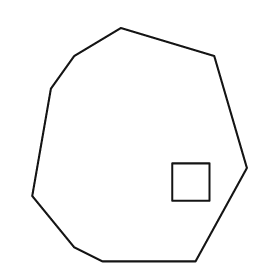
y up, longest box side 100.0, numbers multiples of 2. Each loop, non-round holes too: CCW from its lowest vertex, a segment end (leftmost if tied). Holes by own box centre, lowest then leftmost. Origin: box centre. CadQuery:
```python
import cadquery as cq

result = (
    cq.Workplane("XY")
    .moveTo(-16.0, -50.0)
    .lineTo(24.0, -50.0)
    .lineTo(46.0, -10.0)
    .lineTo(32.0, 38.0)
    .lineTo(-8.0, 50.0)
    .lineTo(-28.0, 38.0)
    .lineTo(-38.0, 24.0)
    .lineTo(-46.0, -22.0)
    .lineTo(-28.0, -44.0)
    .close()
    .moveTo(14.0, -24.0)
    .lineTo(30.0, -24.0)
    .lineTo(30.0, -8.0)
    .lineTo(14.0, -8.0)
    .close()
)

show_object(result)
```